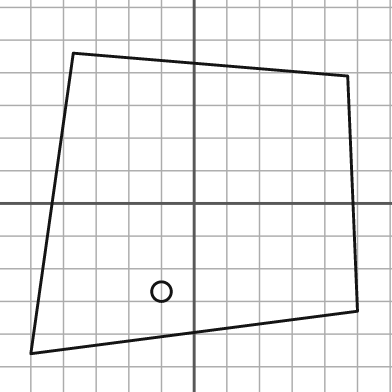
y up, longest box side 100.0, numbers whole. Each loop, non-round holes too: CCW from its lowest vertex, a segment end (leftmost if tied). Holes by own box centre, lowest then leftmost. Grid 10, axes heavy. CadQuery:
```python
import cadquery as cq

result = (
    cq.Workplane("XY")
    .moveTo(-50.0, -46.0)
    .lineTo(50.0, -33.0)
    .lineTo(47.0, 39.0)
    .lineTo(-37.0, 46.0)
    .close()
    .moveTo(-10.0, -27.0)
    .circle(3.0)
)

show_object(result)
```